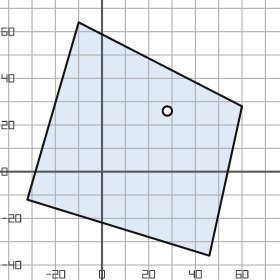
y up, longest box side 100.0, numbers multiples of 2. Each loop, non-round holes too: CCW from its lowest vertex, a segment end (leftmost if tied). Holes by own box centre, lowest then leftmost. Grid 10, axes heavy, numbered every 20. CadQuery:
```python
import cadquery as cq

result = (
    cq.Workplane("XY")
    .moveTo(46.0, -36.0)
    .lineTo(60.0, 28.0)
    .lineTo(-10.0, 64.0)
    .lineTo(-32.0, -12.0)
    .close()
    .moveTo(28.0, 26.0)
    .circle(2.0)
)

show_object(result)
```